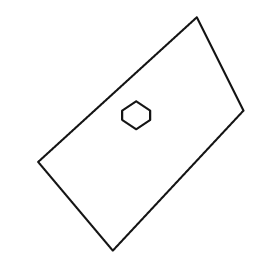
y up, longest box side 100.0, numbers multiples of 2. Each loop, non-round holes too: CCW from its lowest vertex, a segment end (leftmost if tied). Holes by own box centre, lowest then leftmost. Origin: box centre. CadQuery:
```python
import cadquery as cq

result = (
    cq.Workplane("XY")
    .moveTo(-12.0, -50.0)
    .lineTo(44.0, 10.0)
    .lineTo(24.0, 50.0)
    .lineTo(-44.0, -12.0)
    .close()
    .moveTo(-2.0, 2.0)
    .lineTo(4.0, 6.0)
    .lineTo(4.0, 10.0)
    .lineTo(-2.0, 14.0)
    .lineTo(-8.0, 10.0)
    .lineTo(-8.0, 6.0)
    .close()
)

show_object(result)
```